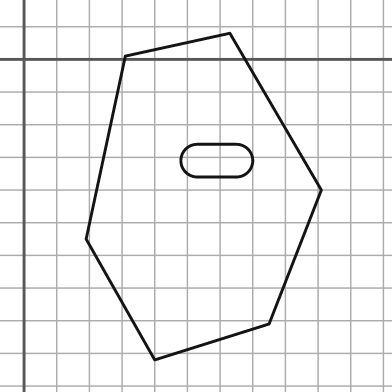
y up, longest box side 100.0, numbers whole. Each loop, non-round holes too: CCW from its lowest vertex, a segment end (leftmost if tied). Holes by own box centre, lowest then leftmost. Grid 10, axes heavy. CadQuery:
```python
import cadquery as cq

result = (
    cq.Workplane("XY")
    .moveTo(40.0, -92.0)
    .lineTo(75.0, -81.0)
    .lineTo(91.0, -40.0)
    .lineTo(63.0, 8.0)
    .lineTo(31.0, 1.0)
    .lineTo(19.0, -55.0)
    .close()
    .moveTo(53.0, -36.0)
    .lineTo(65.0, -36.0)
    .threePointArc((70.0, -31.0), (65.0, -26.0))
    .lineTo(53.0, -26.0)
    .threePointArc((48.0, -31.0), (53.0, -36.0))
    .close()
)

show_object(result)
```